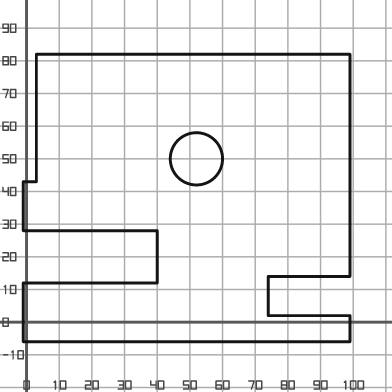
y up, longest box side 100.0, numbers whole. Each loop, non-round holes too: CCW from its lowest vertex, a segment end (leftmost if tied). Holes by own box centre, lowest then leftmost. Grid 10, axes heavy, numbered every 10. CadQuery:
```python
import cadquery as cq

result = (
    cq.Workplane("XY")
    .moveTo(-1.0, -6.0)
    .lineTo(99.0, -6.0)
    .lineTo(99.0, 2.0)
    .lineTo(74.0, 2.0)
    .lineTo(74.0, 14.0)
    .lineTo(99.0, 14.0)
    .lineTo(99.0, 82.0)
    .lineTo(3.0, 82.0)
    .lineTo(3.0, 43.0)
    .lineTo(-1.0, 43.0)
    .lineTo(-1.0, 28.0)
    .lineTo(40.0, 28.0)
    .lineTo(40.0, 12.0)
    .lineTo(-1.0, 12.0)
    .close()
    .moveTo(52.0, 50.0)
    .circle(8.0)
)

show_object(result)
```